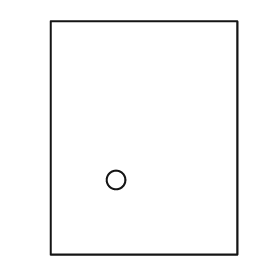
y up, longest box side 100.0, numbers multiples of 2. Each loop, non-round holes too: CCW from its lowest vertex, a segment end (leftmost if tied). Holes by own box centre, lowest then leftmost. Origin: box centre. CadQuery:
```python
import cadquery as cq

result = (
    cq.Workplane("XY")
    .moveTo(-40.0, -50.0)
    .lineTo(40.0, -50.0)
    .lineTo(40.0, 50.0)
    .lineTo(-40.0, 50.0)
    .close()
    .moveTo(-12.0, -18.0)
    .circle(4.0)
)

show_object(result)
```